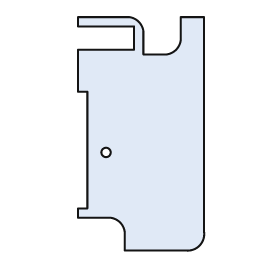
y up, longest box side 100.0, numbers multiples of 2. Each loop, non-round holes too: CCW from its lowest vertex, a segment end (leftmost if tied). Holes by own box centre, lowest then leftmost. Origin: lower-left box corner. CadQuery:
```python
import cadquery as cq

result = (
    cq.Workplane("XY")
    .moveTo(20.0, 0.0)
    .lineTo(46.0, 0.0)
    .threePointArc((52.0, 2.0), (54.0, 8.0))
    .lineTo(54.0, 100.0)
    .lineTo(44.0, 100.0)
    .lineTo(44.0, 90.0)
    .threePointArc((42.0, 86.0), (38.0, 84.0))
    .lineTo(28.0, 84.0)
    .lineTo(28.0, 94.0)
    .threePointArc((26.0, 98.0), (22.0, 100.0))
    .lineTo(0.0, 100.0)
    .lineTo(0.0, 96.0)
    .lineTo(24.0, 96.0)
    .lineTo(24.0, 86.0)
    .lineTo(0.0, 86.0)
    .lineTo(0.0, 68.0)
    .lineTo(4.0, 68.0)
    .lineTo(4.0, 18.0)
    .lineTo(0.0, 18.0)
    .lineTo(0.0, 14.0)
    .lineTo(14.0, 14.0)
    .threePointArc((18.0, 12.0), (20.0, 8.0))
    .close()
    .moveTo(12.0, 42.0)
    .circle(2.0)
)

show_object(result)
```